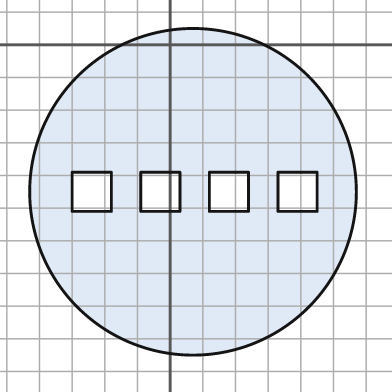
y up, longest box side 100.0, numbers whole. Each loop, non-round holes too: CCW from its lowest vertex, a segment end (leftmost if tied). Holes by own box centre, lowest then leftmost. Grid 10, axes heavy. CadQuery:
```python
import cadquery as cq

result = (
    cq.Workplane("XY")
    .moveTo(7.0, -45.0)
    .circle(50.0)
    .moveTo(-30.0, -51.0)
    .lineTo(-18.0, -51.0)
    .lineTo(-18.0, -39.0)
    .lineTo(-30.0, -39.0)
    .close()
    .moveTo(-9.0, -51.0)
    .lineTo(3.0, -51.0)
    .lineTo(3.0, -39.0)
    .lineTo(-9.0, -39.0)
    .close()
    .moveTo(12.0, -51.0)
    .lineTo(24.0, -51.0)
    .lineTo(24.0, -39.0)
    .lineTo(12.0, -39.0)
    .close()
    .moveTo(33.0, -51.0)
    .lineTo(45.0, -51.0)
    .lineTo(45.0, -39.0)
    .lineTo(33.0, -39.0)
    .close()
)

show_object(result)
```